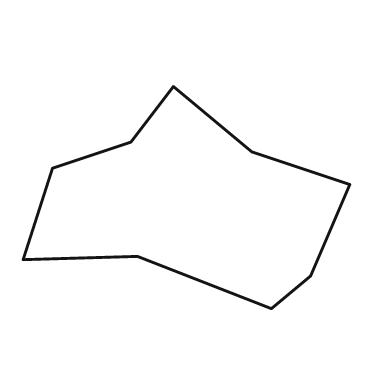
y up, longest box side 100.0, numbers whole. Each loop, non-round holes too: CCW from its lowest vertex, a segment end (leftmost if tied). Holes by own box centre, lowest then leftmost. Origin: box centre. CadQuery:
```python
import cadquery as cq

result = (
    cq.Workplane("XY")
    .moveTo(26.0, -34.0)
    .lineTo(38.0, -24.0)
    .lineTo(50.0, 4.0)
    .lineTo(20.0, 14.0)
    .lineTo(-4.0, 34.0)
    .lineTo(-17.0, 17.0)
    .lineTo(-41.0, 9.0)
    .lineTo(-50.0, -19.0)
    .lineTo(-15.0, -18.0)
    .close()
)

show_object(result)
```